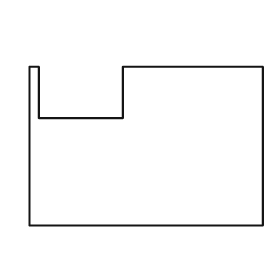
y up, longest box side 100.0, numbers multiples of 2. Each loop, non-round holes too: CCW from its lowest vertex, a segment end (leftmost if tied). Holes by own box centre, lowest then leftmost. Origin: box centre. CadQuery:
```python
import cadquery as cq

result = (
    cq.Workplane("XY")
    .moveTo(-50.0, -34.0)
    .lineTo(50.0, -34.0)
    .lineTo(50.0, 34.0)
    .lineTo(-10.0, 34.0)
    .lineTo(-10.0, 12.0)
    .lineTo(-46.0, 12.0)
    .lineTo(-46.0, 34.0)
    .lineTo(-50.0, 34.0)
    .close()
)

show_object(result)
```